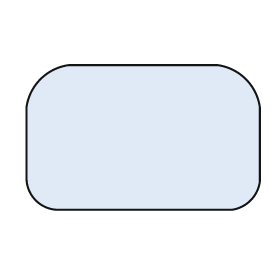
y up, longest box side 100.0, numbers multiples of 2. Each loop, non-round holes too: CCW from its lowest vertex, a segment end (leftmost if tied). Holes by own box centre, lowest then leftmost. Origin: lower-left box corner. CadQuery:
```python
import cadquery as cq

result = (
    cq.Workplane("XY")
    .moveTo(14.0, 0.0)
    .lineTo(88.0, 0.0)
    .threePointArc((96.0, 4.0), (100.0, 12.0))
    .lineTo(100.0, 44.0)
    .threePointArc((94.0, 56.0), (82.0, 62.0))
    .lineTo(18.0, 62.0)
    .threePointArc((6.0, 56.0), (0.0, 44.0))
    .lineTo(0.0, 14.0)
    .threePointArc((4.0, 4.0), (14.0, 0.0))
    .close()
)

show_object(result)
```